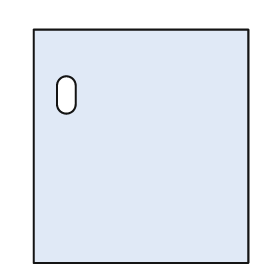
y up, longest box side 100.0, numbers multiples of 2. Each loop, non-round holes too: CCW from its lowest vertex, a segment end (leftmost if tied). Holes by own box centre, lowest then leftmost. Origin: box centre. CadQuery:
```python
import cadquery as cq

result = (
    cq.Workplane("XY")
    .moveTo(-46.0, -50.0)
    .lineTo(46.0, -50.0)
    .lineTo(46.0, 50.0)
    .lineTo(-46.0, 50.0)
    .close()
    .moveTo(-36.0, 18.0)
    .threePointArc((-32.0, 14.0), (-28.0, 18.0))
    .lineTo(-28.0, 26.0)
    .threePointArc((-32.0, 30.0), (-36.0, 26.0))
    .close()
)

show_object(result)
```